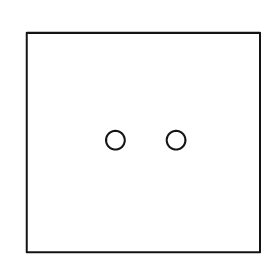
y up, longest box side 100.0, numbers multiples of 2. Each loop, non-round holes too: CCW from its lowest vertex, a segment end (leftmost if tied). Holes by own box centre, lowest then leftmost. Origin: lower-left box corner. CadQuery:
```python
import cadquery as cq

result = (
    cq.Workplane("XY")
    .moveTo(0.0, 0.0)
    .lineTo(100.0, 0.0)
    .lineTo(100.0, 94.0)
    .lineTo(0.0, 94.0)
    .close()
    .moveTo(38.0, 48.0)
    .circle(4.0)
    .moveTo(64.0, 48.0)
    .circle(4.0)
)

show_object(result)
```